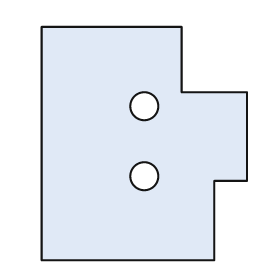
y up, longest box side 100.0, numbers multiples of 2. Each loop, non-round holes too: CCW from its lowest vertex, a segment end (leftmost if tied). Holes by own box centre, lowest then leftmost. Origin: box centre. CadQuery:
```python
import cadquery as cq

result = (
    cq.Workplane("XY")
    .moveTo(-44.0, -50.0)
    .lineTo(30.0, -50.0)
    .lineTo(30.0, -16.0)
    .lineTo(44.0, -16.0)
    .lineTo(44.0, 22.0)
    .lineTo(16.0, 22.0)
    .lineTo(16.0, 50.0)
    .lineTo(-44.0, 50.0)
    .close()
    .moveTo(0.0, -14.0)
    .circle(6.0)
    .moveTo(0.0, 16.0)
    .circle(6.0)
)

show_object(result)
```